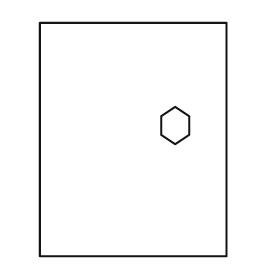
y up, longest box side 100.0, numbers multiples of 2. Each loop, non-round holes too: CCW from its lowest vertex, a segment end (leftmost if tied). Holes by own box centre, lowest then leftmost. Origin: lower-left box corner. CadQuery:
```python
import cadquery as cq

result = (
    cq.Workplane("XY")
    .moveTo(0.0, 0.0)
    .lineTo(80.0, 0.0)
    .lineTo(80.0, 100.0)
    .lineTo(0.0, 100.0)
    .close()
    .moveTo(58.0, 48.0)
    .lineTo(64.0, 52.0)
    .lineTo(64.0, 60.0)
    .lineTo(58.0, 64.0)
    .lineTo(52.0, 60.0)
    .lineTo(52.0, 52.0)
    .close()
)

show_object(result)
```